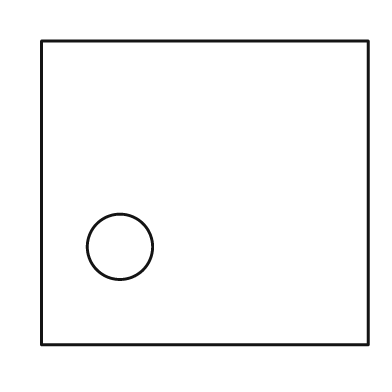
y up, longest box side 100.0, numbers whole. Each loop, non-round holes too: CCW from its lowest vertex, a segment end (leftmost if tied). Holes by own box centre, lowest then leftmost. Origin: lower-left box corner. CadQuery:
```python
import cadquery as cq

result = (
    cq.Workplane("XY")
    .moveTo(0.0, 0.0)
    .lineTo(100.0, 0.0)
    .lineTo(100.0, 93.0)
    .lineTo(0.0, 93.0)
    .close()
    .moveTo(24.0, 30.0)
    .circle(10.0)
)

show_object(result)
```